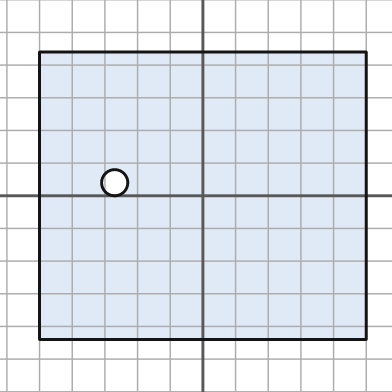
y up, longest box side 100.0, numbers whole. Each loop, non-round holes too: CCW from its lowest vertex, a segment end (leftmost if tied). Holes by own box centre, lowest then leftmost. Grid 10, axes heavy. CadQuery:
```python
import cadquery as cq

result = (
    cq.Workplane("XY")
    .moveTo(-50.0, -44.0)
    .lineTo(50.0, -44.0)
    .lineTo(50.0, 44.0)
    .lineTo(-50.0, 44.0)
    .close()
    .moveTo(-27.0, 4.0)
    .circle(4.0)
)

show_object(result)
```